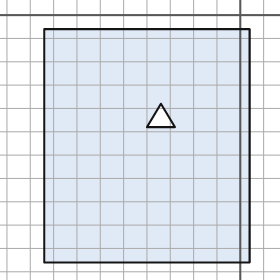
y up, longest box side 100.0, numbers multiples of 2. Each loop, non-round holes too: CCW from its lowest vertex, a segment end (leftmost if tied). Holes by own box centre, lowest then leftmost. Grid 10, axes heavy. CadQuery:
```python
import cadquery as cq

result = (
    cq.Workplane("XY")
    .moveTo(-84.0, -106.0)
    .lineTo(4.0, -106.0)
    .lineTo(4.0, -6.0)
    .lineTo(-84.0, -6.0)
    .close()
    .moveTo(-40.0, -48.0)
    .lineTo(-28.0, -48.0)
    .lineTo(-34.0, -38.0)
    .close()
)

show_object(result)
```